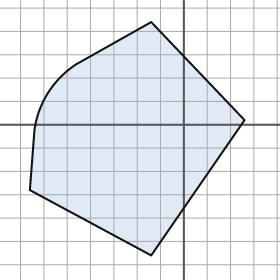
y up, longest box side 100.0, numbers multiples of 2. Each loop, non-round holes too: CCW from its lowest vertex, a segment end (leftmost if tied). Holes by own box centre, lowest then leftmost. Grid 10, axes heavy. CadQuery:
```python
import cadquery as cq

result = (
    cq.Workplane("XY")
    .moveTo(-14.0, -56.0)
    .lineTo(26.0, 2.0)
    .lineTo(-14.0, 44.0)
    .lineTo(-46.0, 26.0)
    .threePointArc((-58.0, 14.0), (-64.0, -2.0))
    .lineTo(-66.0, -28.0)
    .close()
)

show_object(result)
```